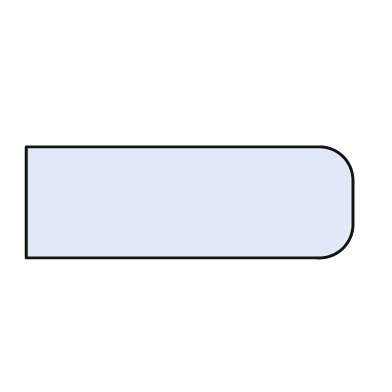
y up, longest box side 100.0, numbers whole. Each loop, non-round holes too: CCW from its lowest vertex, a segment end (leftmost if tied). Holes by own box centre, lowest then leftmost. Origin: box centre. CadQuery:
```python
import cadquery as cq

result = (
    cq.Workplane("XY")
    .moveTo(-50.0, -17.0)
    .lineTo(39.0, -17.0)
    .threePointArc((47.0, -14.0), (50.0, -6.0))
    .lineTo(50.0, 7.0)
    .threePointArc((47.0, 14.0), (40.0, 17.0))
    .lineTo(-50.0, 17.0)
    .close()
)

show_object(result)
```